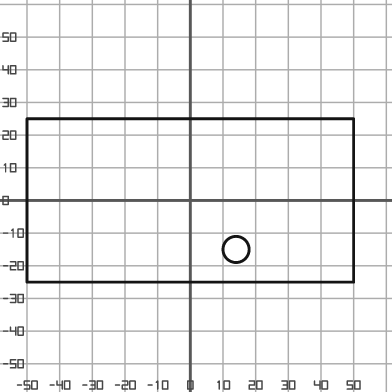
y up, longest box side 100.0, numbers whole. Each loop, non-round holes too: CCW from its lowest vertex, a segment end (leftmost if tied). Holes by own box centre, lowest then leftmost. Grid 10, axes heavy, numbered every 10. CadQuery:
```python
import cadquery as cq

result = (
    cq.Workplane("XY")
    .moveTo(-50.0, -25.0)
    .lineTo(50.0, -25.0)
    .lineTo(50.0, 25.0)
    .lineTo(-50.0, 25.0)
    .close()
    .moveTo(14.0, -15.0)
    .circle(4.0)
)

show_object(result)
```